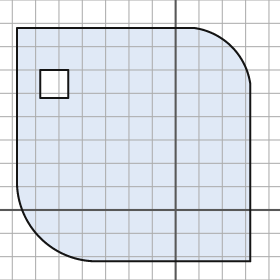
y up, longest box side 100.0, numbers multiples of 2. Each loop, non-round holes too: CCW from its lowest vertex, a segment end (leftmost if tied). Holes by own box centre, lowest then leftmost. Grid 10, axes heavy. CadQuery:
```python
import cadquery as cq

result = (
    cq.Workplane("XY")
    .moveTo(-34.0, -22.0)
    .lineTo(32.0, -22.0)
    .lineTo(32.0, 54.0)
    .threePointArc((24.0, 70.0), (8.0, 78.0))
    .lineTo(-68.0, 78.0)
    .lineTo(-68.0, 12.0)
    .threePointArc((-58.0, -12.0), (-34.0, -22.0))
    .close()
    .moveTo(-58.0, 48.0)
    .lineTo(-46.0, 48.0)
    .lineTo(-46.0, 60.0)
    .lineTo(-58.0, 60.0)
    .close()
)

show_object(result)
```